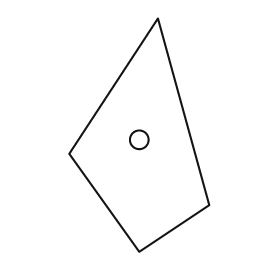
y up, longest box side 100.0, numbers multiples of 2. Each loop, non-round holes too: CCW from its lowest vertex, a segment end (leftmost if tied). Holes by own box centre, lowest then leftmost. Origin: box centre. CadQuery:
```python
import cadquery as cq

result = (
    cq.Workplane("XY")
    .moveTo(0.0, -50.0)
    .lineTo(30.0, -30.0)
    .lineTo(8.0, 50.0)
    .lineTo(-30.0, -8.0)
    .close()
    .moveTo(0.0, -2.0)
    .circle(4.0)
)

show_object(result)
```